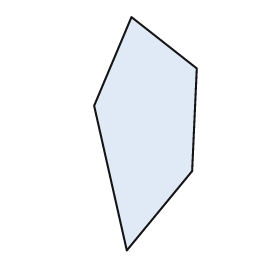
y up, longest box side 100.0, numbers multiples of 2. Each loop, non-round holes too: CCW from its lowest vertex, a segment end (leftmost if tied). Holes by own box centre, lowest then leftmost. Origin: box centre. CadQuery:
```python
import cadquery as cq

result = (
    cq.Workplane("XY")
    .moveTo(-8.0, -50.0)
    .lineTo(20.0, -16.0)
    .lineTo(22.0, 28.0)
    .lineTo(-6.0, 50.0)
    .lineTo(-22.0, 12.0)
    .close()
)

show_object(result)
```